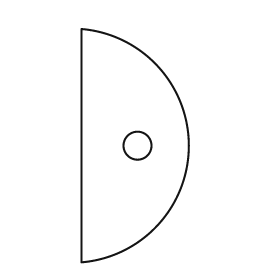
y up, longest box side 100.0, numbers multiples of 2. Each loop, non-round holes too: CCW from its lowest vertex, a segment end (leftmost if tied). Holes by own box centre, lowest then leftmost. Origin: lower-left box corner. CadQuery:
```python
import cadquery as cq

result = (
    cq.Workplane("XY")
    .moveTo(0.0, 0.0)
    .threePointArc((46.0, 50.0), (0.0, 100.0))
    .close()
    .moveTo(24.0, 50.0)
    .circle(6.0)
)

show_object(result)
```